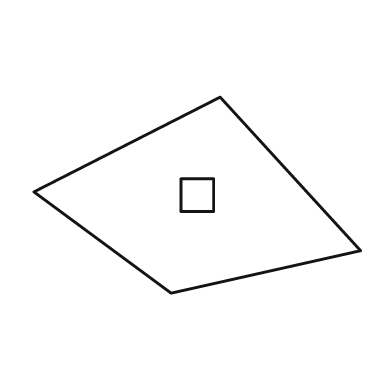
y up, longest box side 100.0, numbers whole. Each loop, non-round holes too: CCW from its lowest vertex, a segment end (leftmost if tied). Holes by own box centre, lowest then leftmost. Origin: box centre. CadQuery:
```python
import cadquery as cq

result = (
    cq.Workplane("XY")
    .moveTo(-8.0, -30.0)
    .lineTo(50.0, -17.0)
    .lineTo(7.0, 30.0)
    .lineTo(-50.0, 1.0)
    .close()
    .moveTo(-5.0, -5.0)
    .lineTo(5.0, -5.0)
    .lineTo(5.0, 5.0)
    .lineTo(-5.0, 5.0)
    .close()
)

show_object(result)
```